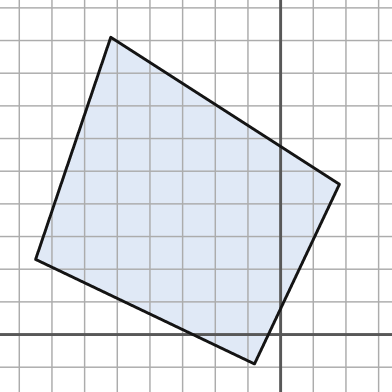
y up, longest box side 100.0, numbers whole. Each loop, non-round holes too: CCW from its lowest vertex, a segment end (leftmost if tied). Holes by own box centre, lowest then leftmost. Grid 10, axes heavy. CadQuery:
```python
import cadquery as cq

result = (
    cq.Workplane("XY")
    .moveTo(-8.0, -9.0)
    .lineTo(18.0, 46.0)
    .lineTo(-52.0, 91.0)
    .lineTo(-75.0, 23.0)
    .close()
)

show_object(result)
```